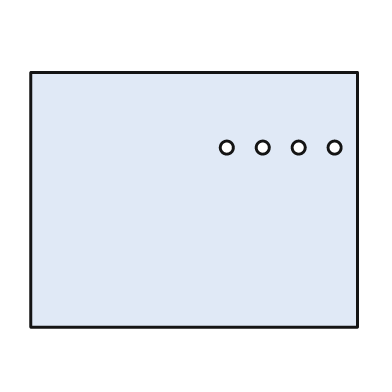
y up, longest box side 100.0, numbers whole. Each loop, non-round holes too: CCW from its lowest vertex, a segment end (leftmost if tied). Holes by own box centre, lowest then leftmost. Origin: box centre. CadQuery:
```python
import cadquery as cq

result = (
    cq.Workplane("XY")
    .moveTo(-50.0, -39.0)
    .lineTo(50.0, -39.0)
    .lineTo(50.0, 39.0)
    .lineTo(-50.0, 39.0)
    .close()
    .moveTo(10.0, 16.0)
    .circle(2.0)
    .moveTo(21.0, 16.0)
    .circle(2.0)
    .moveTo(32.0, 16.0)
    .circle(2.0)
    .moveTo(43.0, 16.0)
    .circle(2.0)
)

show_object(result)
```